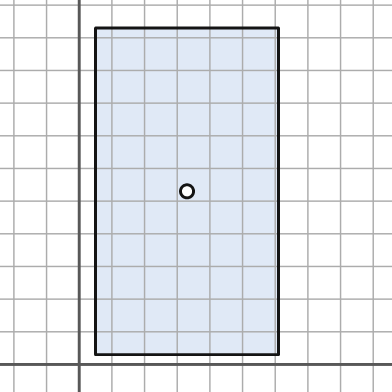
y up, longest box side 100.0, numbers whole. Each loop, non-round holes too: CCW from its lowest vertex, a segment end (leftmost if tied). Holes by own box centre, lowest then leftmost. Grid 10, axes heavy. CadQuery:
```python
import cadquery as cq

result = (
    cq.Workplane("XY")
    .moveTo(5.0, 3.0)
    .lineTo(61.0, 3.0)
    .lineTo(61.0, 103.0)
    .lineTo(5.0, 103.0)
    .close()
    .moveTo(33.0, 53.0)
    .circle(2.0)
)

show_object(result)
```